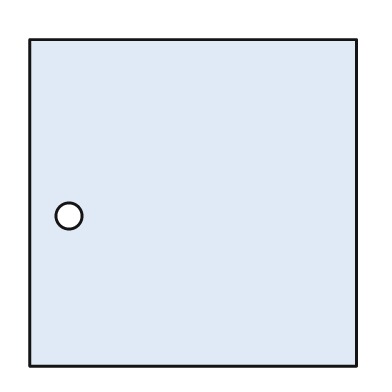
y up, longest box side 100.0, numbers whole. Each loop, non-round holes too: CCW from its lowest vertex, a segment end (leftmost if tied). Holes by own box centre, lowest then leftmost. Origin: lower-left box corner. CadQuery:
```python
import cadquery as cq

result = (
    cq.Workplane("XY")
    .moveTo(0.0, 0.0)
    .lineTo(100.0, 0.0)
    .lineTo(100.0, 100.0)
    .lineTo(0.0, 100.0)
    .close()
    .moveTo(12.0, 46.0)
    .circle(4.0)
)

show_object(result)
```